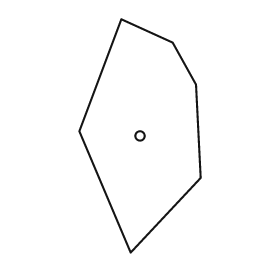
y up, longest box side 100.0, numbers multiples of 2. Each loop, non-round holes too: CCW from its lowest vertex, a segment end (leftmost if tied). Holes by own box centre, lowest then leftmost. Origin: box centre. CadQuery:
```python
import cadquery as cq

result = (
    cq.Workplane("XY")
    .moveTo(-4.0, -50.0)
    .lineTo(26.0, -18.0)
    .lineTo(24.0, 22.0)
    .lineTo(14.0, 40.0)
    .lineTo(-8.0, 50.0)
    .lineTo(-26.0, 2.0)
    .close()
    .moveTo(0.0, 0.0)
    .circle(2.0)
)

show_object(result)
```